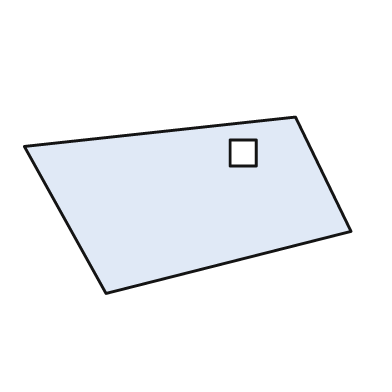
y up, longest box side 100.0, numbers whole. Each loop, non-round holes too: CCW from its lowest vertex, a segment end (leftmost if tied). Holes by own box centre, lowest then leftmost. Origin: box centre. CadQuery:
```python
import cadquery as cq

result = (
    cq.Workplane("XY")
    .moveTo(-25.0, -27.0)
    .lineTo(50.0, -8.0)
    .lineTo(33.0, 27.0)
    .lineTo(-50.0, 18.0)
    .close()
    .moveTo(13.0, 12.0)
    .lineTo(21.0, 12.0)
    .lineTo(21.0, 20.0)
    .lineTo(13.0, 20.0)
    .close()
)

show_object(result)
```